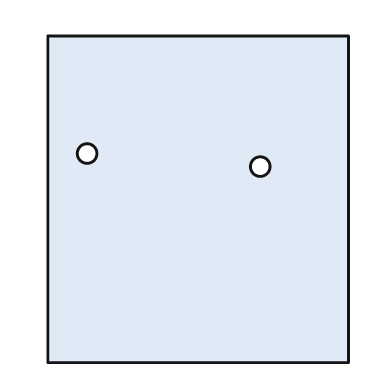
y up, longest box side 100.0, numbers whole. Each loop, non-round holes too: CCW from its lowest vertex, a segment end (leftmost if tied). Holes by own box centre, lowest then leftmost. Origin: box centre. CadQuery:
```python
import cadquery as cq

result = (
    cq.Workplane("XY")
    .moveTo(-46.0, -50.0)
    .lineTo(46.0, -50.0)
    .lineTo(46.0, 50.0)
    .lineTo(-46.0, 50.0)
    .close()
    .moveTo(19.0, 10.0)
    .circle(3.0)
    .moveTo(-34.0, 14.0)
    .circle(3.0)
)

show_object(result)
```